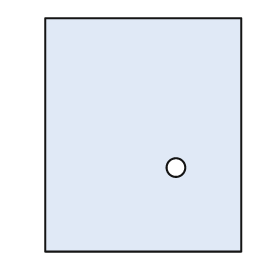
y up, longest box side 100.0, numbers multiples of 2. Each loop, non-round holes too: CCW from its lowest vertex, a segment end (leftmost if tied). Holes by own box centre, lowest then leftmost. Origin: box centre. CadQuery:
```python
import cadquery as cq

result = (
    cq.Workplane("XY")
    .moveTo(-42.0, -50.0)
    .lineTo(42.0, -50.0)
    .lineTo(42.0, 50.0)
    .lineTo(-42.0, 50.0)
    .close()
    .moveTo(14.0, -14.0)
    .circle(4.0)
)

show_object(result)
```